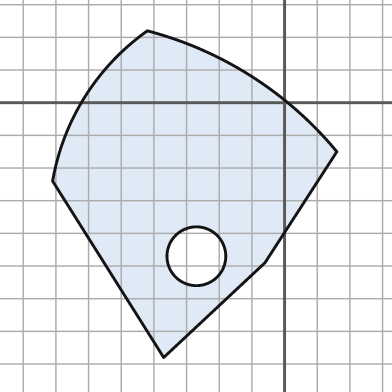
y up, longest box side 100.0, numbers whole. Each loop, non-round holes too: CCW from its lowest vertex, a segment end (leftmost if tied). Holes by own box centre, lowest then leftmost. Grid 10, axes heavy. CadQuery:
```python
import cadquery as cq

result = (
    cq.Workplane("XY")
    .moveTo(-37.0, -78.0)
    .lineTo(-6.0, -49.0)
    .lineTo(16.0, -15.0)
    .threePointArc((-10.0, 8.0), (-42.0, 22.0))
    .threePointArc((-61.0, 2.0), (-71.0, -24.0))
    .close()
    .moveTo(-27.0, -47.0)
    .circle(9.0)
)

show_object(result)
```